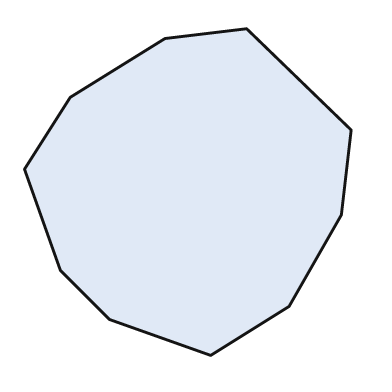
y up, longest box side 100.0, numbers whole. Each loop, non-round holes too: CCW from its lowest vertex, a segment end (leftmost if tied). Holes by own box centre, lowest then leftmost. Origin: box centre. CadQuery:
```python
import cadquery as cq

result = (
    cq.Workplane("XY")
    .moveTo(7.0, -50.0)
    .lineTo(31.0, -35.0)
    .lineTo(47.0, -7.0)
    .lineTo(50.0, 19.0)
    .lineTo(18.0, 50.0)
    .lineTo(-7.0, 47.0)
    .lineTo(-36.0, 29.0)
    .lineTo(-50.0, 7.0)
    .lineTo(-39.0, -24.0)
    .lineTo(-24.0, -39.0)
    .close()
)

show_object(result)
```